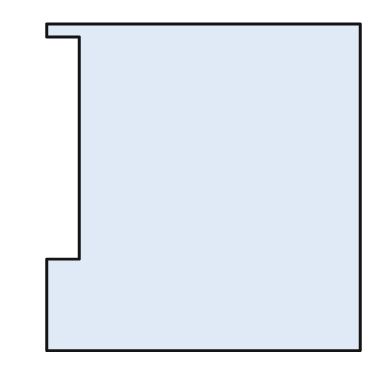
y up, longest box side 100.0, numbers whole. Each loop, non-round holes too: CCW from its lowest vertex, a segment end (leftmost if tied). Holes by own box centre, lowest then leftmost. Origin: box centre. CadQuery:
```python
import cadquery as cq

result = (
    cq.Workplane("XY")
    .moveTo(-48.0, -50.0)
    .lineTo(48.0, -50.0)
    .lineTo(48.0, 50.0)
    .lineTo(-48.0, 50.0)
    .lineTo(-48.0, 46.0)
    .lineTo(-38.0, 46.0)
    .lineTo(-38.0, -22.0)
    .lineTo(-48.0, -22.0)
    .close()
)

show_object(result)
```